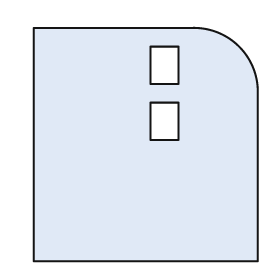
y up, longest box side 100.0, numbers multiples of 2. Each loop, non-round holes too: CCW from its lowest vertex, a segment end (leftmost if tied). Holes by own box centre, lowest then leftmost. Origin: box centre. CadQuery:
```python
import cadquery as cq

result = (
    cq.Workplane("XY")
    .moveTo(-48.0, -50.0)
    .lineTo(48.0, -50.0)
    .lineTo(48.0, 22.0)
    .threePointArc((40.0, 42.0), (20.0, 50.0))
    .lineTo(-48.0, 50.0)
    .close()
    .moveTo(2.0, 2.0)
    .lineTo(14.0, 2.0)
    .lineTo(14.0, 18.0)
    .lineTo(2.0, 18.0)
    .close()
    .moveTo(2.0, 26.0)
    .lineTo(14.0, 26.0)
    .lineTo(14.0, 42.0)
    .lineTo(2.0, 42.0)
    .close()
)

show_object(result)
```